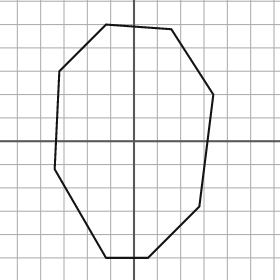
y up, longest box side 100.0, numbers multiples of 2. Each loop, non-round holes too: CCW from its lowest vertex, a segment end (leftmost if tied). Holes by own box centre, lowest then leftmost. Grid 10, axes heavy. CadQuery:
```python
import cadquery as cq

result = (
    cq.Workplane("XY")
    .moveTo(-12.0, -50.0)
    .lineTo(6.0, -50.0)
    .lineTo(28.0, -28.0)
    .lineTo(34.0, 20.0)
    .lineTo(16.0, 48.0)
    .lineTo(-12.0, 50.0)
    .lineTo(-32.0, 30.0)
    .lineTo(-34.0, -12.0)
    .close()
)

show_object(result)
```